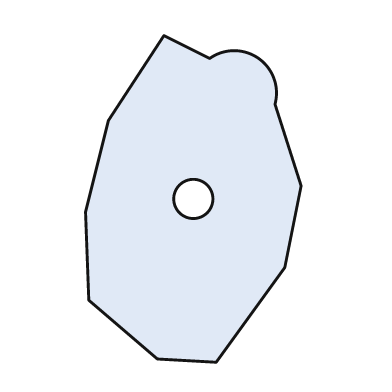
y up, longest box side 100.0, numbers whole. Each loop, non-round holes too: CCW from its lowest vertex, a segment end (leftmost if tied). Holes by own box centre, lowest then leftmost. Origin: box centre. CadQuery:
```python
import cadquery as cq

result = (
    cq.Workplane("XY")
    .moveTo(7.0, -50.0)
    .lineTo(28.0, -21.0)
    .lineTo(33.0, 4.0)
    .lineTo(25.0, 29.0)
    .threePointArc((20.0, 43.0), (5.0, 43.0))
    .lineTo(-9.0, 50.0)
    .lineTo(-26.0, 24.0)
    .lineTo(-33.0, -4.0)
    .lineTo(-32.0, -31.0)
    .lineTo(-11.0, -49.0)
    .close()
    .moveTo(0.0, 0.0)
    .circle(6.0)
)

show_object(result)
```